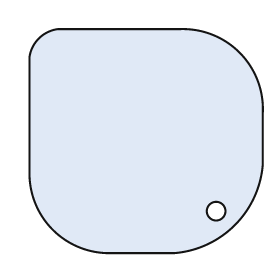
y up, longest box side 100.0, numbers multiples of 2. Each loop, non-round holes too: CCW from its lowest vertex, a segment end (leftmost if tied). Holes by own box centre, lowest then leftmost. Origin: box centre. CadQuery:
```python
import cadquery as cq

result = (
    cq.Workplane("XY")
    .moveTo(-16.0, -48.0)
    .lineTo(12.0, -48.0)
    .threePointArc((38.0, -36.0), (50.0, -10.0))
    .lineTo(50.0, 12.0)
    .threePointArc((40.0, 38.0), (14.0, 48.0))
    .lineTo(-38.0, 48.0)
    .threePointArc((-46.0, 44.0), (-50.0, 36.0))
    .lineTo(-50.0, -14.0)
    .threePointArc((-40.0, -38.0), (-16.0, -48.0))
    .close()
    .moveTo(30.0, -30.0)
    .circle(4.0)
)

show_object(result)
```